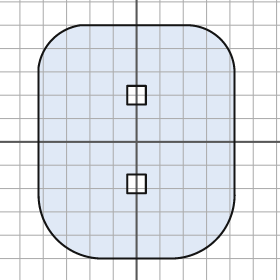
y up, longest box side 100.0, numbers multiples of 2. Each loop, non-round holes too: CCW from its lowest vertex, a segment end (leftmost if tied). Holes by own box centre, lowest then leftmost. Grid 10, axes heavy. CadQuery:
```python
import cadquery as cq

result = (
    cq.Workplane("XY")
    .moveTo(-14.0, -50.0)
    .lineTo(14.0, -50.0)
    .threePointArc((34.0, -42.0), (42.0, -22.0))
    .lineTo(42.0, 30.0)
    .threePointArc((36.0, 44.0), (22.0, 50.0))
    .lineTo(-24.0, 50.0)
    .threePointArc((-36.0, 44.0), (-42.0, 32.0))
    .lineTo(-42.0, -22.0)
    .threePointArc((-34.0, -42.0), (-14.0, -50.0))
    .close()
    .moveTo(-4.0, -22.0)
    .lineTo(4.0, -22.0)
    .lineTo(4.0, -14.0)
    .lineTo(-4.0, -14.0)
    .close()
    .moveTo(-4.0, 16.0)
    .lineTo(4.0, 16.0)
    .lineTo(4.0, 24.0)
    .lineTo(-4.0, 24.0)
    .close()
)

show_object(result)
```